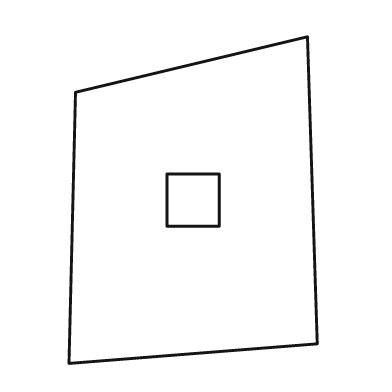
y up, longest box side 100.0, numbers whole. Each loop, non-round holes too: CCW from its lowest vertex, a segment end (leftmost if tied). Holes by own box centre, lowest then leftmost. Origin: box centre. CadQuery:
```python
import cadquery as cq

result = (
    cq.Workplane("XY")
    .moveTo(-38.0, -50.0)
    .lineTo(38.0, -44.0)
    .lineTo(35.0, 50.0)
    .lineTo(-36.0, 33.0)
    .close()
    .moveTo(-8.0, -8.0)
    .lineTo(8.0, -8.0)
    .lineTo(8.0, 8.0)
    .lineTo(-8.0, 8.0)
    .close()
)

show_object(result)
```